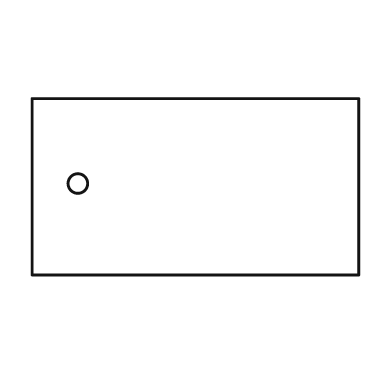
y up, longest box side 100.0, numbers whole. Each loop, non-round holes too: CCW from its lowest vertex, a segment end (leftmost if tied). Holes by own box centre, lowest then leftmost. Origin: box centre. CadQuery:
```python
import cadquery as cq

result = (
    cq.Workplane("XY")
    .moveTo(-50.0, -27.0)
    .lineTo(50.0, -27.0)
    .lineTo(50.0, 27.0)
    .lineTo(-50.0, 27.0)
    .close()
    .moveTo(-36.0, 1.0)
    .circle(3.0)
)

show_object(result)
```